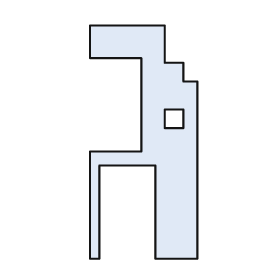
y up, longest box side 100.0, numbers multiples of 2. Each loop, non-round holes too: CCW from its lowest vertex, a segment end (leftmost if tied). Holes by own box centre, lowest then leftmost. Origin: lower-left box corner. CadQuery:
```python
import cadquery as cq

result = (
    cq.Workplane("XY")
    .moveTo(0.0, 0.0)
    .lineTo(4.0, 0.0)
    .lineTo(4.0, 40.0)
    .lineTo(28.0, 40.0)
    .lineTo(28.0, 0.0)
    .lineTo(46.0, 0.0)
    .lineTo(46.0, 76.0)
    .lineTo(40.0, 76.0)
    .lineTo(40.0, 84.0)
    .lineTo(32.0, 84.0)
    .lineTo(32.0, 100.0)
    .lineTo(0.0, 100.0)
    .lineTo(0.0, 86.0)
    .lineTo(22.0, 86.0)
    .lineTo(22.0, 46.0)
    .lineTo(0.0, 46.0)
    .close()
    .moveTo(32.0, 56.0)
    .lineTo(40.0, 56.0)
    .lineTo(40.0, 64.0)
    .lineTo(32.0, 64.0)
    .close()
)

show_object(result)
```